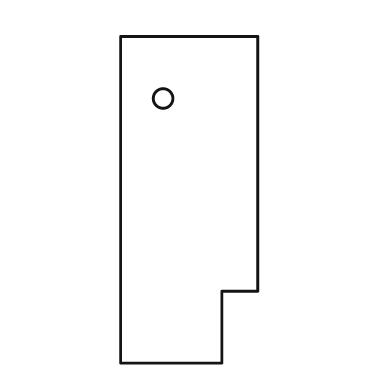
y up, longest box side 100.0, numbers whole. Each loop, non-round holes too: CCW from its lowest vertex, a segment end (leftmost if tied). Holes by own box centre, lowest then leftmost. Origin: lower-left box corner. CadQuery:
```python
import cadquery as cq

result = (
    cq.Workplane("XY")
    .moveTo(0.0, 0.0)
    .lineTo(31.0, 0.0)
    .lineTo(31.0, 22.0)
    .lineTo(42.0, 22.0)
    .lineTo(42.0, 100.0)
    .lineTo(0.0, 100.0)
    .close()
    .moveTo(13.0, 81.0)
    .circle(3.0)
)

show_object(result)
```